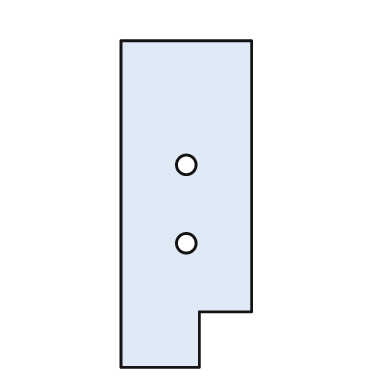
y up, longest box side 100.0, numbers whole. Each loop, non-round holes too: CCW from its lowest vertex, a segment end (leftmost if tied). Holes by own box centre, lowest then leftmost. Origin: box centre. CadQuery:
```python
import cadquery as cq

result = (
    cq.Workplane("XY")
    .moveTo(-20.0, -50.0)
    .lineTo(4.0, -50.0)
    .lineTo(4.0, -33.0)
    .lineTo(20.0, -33.0)
    .lineTo(20.0, 50.0)
    .lineTo(-20.0, 50.0)
    .close()
    .moveTo(0.0, -12.0)
    .circle(3.0)
    .moveTo(0.0, 12.0)
    .circle(3.0)
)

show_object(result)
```